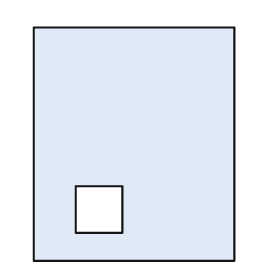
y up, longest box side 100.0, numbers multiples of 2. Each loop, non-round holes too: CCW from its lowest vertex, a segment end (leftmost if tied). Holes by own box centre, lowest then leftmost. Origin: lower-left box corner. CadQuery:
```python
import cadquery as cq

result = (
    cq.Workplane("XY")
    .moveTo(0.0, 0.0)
    .lineTo(86.0, 0.0)
    .lineTo(86.0, 100.0)
    .lineTo(0.0, 100.0)
    .close()
    .moveTo(18.0, 12.0)
    .lineTo(38.0, 12.0)
    .lineTo(38.0, 32.0)
    .lineTo(18.0, 32.0)
    .close()
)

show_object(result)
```